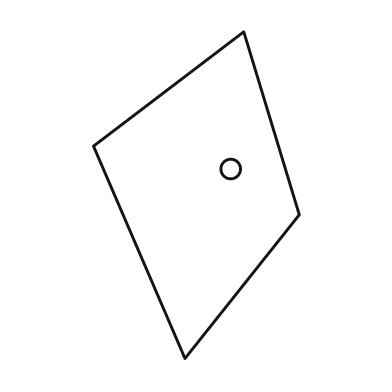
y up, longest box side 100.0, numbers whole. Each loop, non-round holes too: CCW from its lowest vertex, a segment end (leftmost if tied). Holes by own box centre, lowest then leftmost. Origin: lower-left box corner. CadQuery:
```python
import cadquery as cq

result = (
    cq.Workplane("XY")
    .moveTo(28.0, 0.0)
    .lineTo(63.0, 44.0)
    .lineTo(46.0, 100.0)
    .lineTo(0.0, 65.0)
    .close()
    .moveTo(42.0, 58.0)
    .circle(3.0)
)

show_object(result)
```